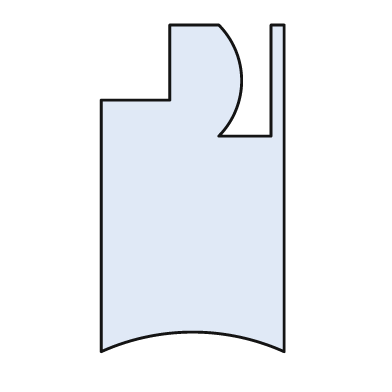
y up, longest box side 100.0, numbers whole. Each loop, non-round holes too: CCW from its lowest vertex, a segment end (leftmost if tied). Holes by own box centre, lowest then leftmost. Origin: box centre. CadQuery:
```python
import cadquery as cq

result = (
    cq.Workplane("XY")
    .moveTo(-28.0, -50.0)
    .threePointArc((0.0, -44.0), (28.0, -50.0))
    .lineTo(28.0, 50.0)
    .lineTo(24.0, 50.0)
    .lineTo(24.0, 16.0)
    .lineTo(8.0, 16.0)
    .threePointArc((15.0, 33.0), (8.0, 50.0))
    .lineTo(-7.0, 50.0)
    .lineTo(-7.0, 27.0)
    .lineTo(-28.0, 27.0)
    .close()
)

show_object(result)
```